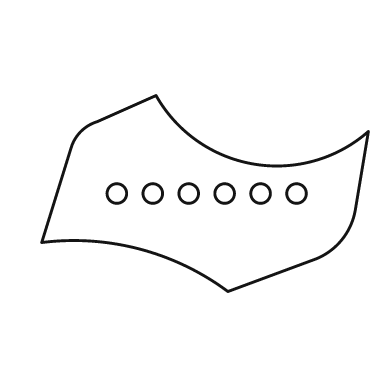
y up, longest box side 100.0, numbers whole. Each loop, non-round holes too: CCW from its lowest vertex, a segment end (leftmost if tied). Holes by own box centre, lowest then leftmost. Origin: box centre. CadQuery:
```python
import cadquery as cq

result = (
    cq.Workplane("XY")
    .moveTo(7.0, -30.0)
    .lineTo(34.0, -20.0)
    .threePointArc((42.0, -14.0), (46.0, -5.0))
    .lineTo(50.0, 19.0)
    .threePointArc((15.0, 9.0), (-15.0, 30.0))
    .lineTo(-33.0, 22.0)
    .threePointArc((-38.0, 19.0), (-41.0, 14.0))
    .lineTo(-50.0, -15.0)
    .threePointArc((-20.0, -17.0), (7.0, -30.0))
    .close()
    .moveTo(-27.0, 0.0)
    .circle(3.0)
    .moveTo(-16.0, 0.0)
    .circle(3.0)
    .moveTo(-5.0, 0.0)
    .circle(3.0)
    .moveTo(6.0, 0.0)
    .circle(3.0)
    .moveTo(17.0, 0.0)
    .circle(3.0)
    .moveTo(28.0, 0.0)
    .circle(3.0)
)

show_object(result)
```